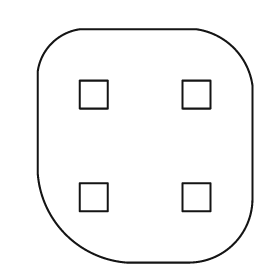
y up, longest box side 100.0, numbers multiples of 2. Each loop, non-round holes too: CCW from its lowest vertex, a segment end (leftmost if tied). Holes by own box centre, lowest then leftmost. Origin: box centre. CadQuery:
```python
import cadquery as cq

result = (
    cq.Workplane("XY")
    .moveTo(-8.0, -50.0)
    .lineTo(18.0, -50.0)
    .threePointArc((38.0, -42.0), (46.0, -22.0))
    .lineTo(46.0, 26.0)
    .threePointArc((38.0, 42.0), (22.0, 50.0))
    .lineTo(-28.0, 50.0)
    .threePointArc((-40.0, 44.0), (-46.0, 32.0))
    .lineTo(-46.0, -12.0)
    .threePointArc((-34.0, -38.0), (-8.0, -50.0))
    .close()
    .moveTo(-28.0, -28.0)
    .lineTo(-16.0, -28.0)
    .lineTo(-16.0, -16.0)
    .lineTo(-28.0, -16.0)
    .close()
    .moveTo(16.0, -28.0)
    .lineTo(28.0, -28.0)
    .lineTo(28.0, -16.0)
    .lineTo(16.0, -16.0)
    .close()
    .moveTo(-28.0, 16.0)
    .lineTo(-16.0, 16.0)
    .lineTo(-16.0, 28.0)
    .lineTo(-28.0, 28.0)
    .close()
    .moveTo(16.0, 16.0)
    .lineTo(28.0, 16.0)
    .lineTo(28.0, 28.0)
    .lineTo(16.0, 28.0)
    .close()
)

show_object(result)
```